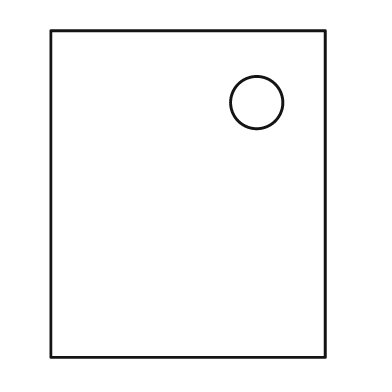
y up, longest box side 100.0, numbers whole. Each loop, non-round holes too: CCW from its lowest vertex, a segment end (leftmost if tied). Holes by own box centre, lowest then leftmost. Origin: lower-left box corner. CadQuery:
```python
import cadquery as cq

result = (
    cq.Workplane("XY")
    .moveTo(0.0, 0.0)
    .lineTo(84.0, 0.0)
    .lineTo(84.0, 100.0)
    .lineTo(0.0, 100.0)
    .close()
    .moveTo(63.0, 78.0)
    .circle(8.0)
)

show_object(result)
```